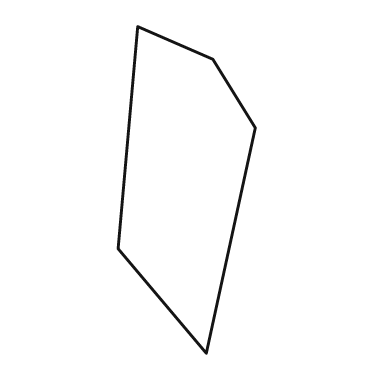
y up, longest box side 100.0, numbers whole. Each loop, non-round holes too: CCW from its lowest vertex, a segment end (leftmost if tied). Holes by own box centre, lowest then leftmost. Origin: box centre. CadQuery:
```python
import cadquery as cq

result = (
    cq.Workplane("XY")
    .moveTo(6.0, -50.0)
    .lineTo(21.0, 19.0)
    .lineTo(8.0, 40.0)
    .lineTo(-15.0, 50.0)
    .lineTo(-21.0, -18.0)
    .close()
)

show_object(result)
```